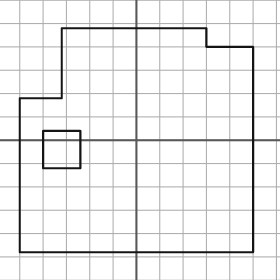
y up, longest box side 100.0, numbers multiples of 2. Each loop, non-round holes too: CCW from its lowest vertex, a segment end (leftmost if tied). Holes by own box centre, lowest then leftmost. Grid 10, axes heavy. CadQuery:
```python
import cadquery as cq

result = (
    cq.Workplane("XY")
    .moveTo(-50.0, -48.0)
    .lineTo(50.0, -48.0)
    .lineTo(50.0, 40.0)
    .lineTo(30.0, 40.0)
    .lineTo(30.0, 48.0)
    .lineTo(-32.0, 48.0)
    .lineTo(-32.0, 18.0)
    .lineTo(-50.0, 18.0)
    .close()
    .moveTo(-40.0, -12.0)
    .lineTo(-24.0, -12.0)
    .lineTo(-24.0, 4.0)
    .lineTo(-40.0, 4.0)
    .close()
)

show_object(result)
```